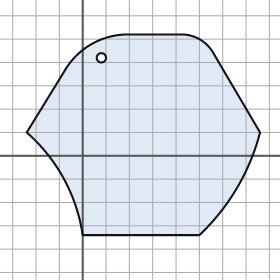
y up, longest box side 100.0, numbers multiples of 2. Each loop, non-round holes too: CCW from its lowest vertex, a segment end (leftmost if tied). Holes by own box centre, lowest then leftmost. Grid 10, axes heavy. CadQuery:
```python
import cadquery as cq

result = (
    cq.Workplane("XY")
    .moveTo(0.0, -34.0)
    .lineTo(50.0, -34.0)
    .threePointArc((66.0, -14.0), (76.0, 10.0))
    .lineTo(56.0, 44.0)
    .threePointArc((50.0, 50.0), (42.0, 52.0))
    .lineTo(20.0, 52.0)
    .threePointArc((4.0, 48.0), (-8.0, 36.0))
    .lineTo(-24.0, 10.0)
    .threePointArc((-8.0, -10.0), (0.0, -34.0))
    .close()
    .moveTo(8.0, 42.0)
    .circle(2.0)
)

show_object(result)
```